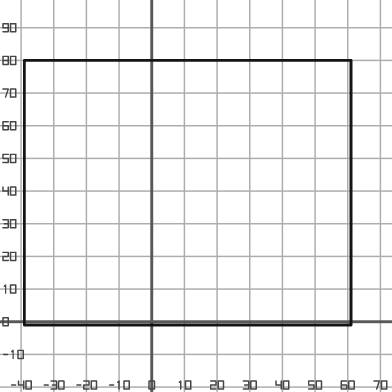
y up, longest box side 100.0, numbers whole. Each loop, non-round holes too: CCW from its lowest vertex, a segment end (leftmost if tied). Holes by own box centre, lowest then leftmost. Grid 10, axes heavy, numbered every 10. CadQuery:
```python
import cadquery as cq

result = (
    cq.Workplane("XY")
    .moveTo(-39.0, -1.0)
    .lineTo(61.0, -1.0)
    .lineTo(61.0, 80.0)
    .lineTo(-39.0, 80.0)
    .close()
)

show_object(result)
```